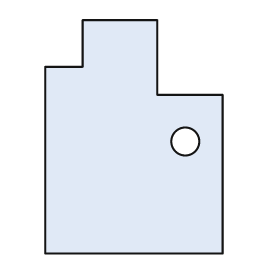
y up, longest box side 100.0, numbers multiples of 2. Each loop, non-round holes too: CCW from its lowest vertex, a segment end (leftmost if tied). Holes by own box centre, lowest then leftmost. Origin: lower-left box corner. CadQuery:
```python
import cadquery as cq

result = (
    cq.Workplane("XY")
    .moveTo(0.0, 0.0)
    .lineTo(76.0, 0.0)
    .lineTo(76.0, 68.0)
    .lineTo(48.0, 68.0)
    .lineTo(48.0, 100.0)
    .lineTo(16.0, 100.0)
    .lineTo(16.0, 80.0)
    .lineTo(0.0, 80.0)
    .close()
    .moveTo(60.0, 48.0)
    .circle(6.0)
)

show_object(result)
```